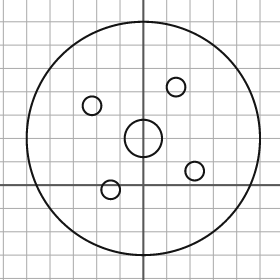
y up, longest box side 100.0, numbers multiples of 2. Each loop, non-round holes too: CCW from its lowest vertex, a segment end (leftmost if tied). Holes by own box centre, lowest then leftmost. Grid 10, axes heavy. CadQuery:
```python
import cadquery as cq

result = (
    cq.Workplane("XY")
    .moveTo(0.0, 20.0)
    .circle(50.0)
    .moveTo(-14.0, -2.0)
    .circle(4.0)
    .moveTo(22.0, 6.0)
    .circle(4.0)
    .moveTo(0.0, 20.0)
    .circle(8.0)
    .moveTo(-22.0, 34.0)
    .circle(4.0)
    .moveTo(14.0, 42.0)
    .circle(4.0)
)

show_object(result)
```